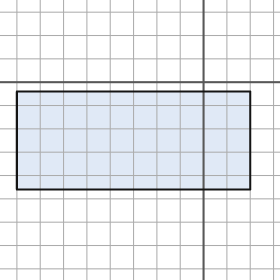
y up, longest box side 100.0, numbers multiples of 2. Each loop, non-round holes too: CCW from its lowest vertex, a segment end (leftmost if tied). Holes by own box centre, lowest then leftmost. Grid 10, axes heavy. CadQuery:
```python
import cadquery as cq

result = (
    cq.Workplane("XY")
    .moveTo(-80.0, -46.0)
    .lineTo(20.0, -46.0)
    .lineTo(20.0, -4.0)
    .lineTo(-80.0, -4.0)
    .close()
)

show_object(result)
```